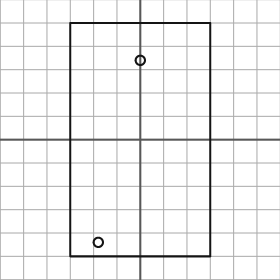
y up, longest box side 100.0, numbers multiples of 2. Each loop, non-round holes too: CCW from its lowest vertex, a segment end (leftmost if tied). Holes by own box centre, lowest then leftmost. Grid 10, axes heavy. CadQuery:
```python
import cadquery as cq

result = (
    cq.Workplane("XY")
    .moveTo(-30.0, -50.0)
    .lineTo(30.0, -50.0)
    .lineTo(30.0, 50.0)
    .lineTo(-30.0, 50.0)
    .close()
    .moveTo(-18.0, -44.0)
    .circle(2.0)
    .moveTo(0.0, 34.0)
    .circle(2.0)
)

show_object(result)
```